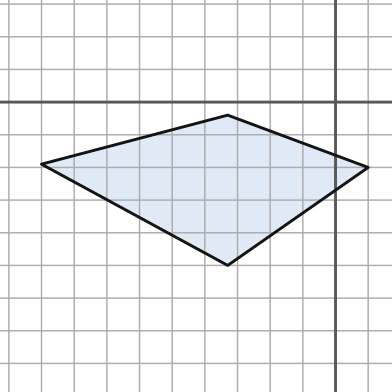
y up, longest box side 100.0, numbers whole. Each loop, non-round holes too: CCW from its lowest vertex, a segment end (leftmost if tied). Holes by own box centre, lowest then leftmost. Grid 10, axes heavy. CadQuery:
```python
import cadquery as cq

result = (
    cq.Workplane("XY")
    .moveTo(-33.0, -50.0)
    .lineTo(10.0, -20.0)
    .lineTo(-33.0, -4.0)
    .lineTo(-90.0, -19.0)
    .close()
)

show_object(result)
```